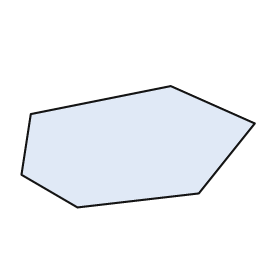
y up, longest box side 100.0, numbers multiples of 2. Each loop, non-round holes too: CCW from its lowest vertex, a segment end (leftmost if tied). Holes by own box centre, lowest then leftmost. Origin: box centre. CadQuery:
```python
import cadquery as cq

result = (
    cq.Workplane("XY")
    .moveTo(-26.0, -26.0)
    .lineTo(26.0, -20.0)
    .lineTo(50.0, 10.0)
    .lineTo(14.0, 26.0)
    .lineTo(-46.0, 14.0)
    .lineTo(-50.0, -12.0)
    .close()
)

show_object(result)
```